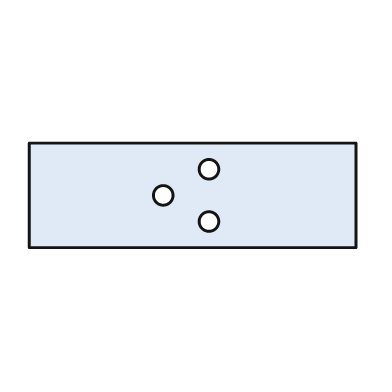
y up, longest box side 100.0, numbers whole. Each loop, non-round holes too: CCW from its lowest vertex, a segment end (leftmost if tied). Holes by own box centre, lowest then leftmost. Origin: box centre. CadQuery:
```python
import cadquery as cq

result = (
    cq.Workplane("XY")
    .moveTo(-50.0, -16.0)
    .lineTo(50.0, -16.0)
    .lineTo(50.0, 16.0)
    .lineTo(-50.0, 16.0)
    .close()
    .moveTo(5.0, -8.0)
    .circle(3.0)
    .moveTo(-9.0, 0.0)
    .circle(3.0)
    .moveTo(5.0, 8.0)
    .circle(3.0)
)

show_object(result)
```